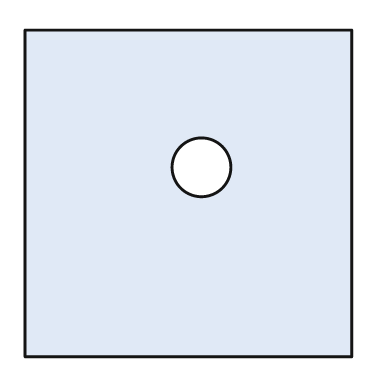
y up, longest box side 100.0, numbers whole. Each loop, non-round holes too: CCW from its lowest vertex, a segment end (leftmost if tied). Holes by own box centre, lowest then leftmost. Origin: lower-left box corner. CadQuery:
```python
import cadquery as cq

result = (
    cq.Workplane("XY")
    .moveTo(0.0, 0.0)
    .lineTo(100.0, 0.0)
    .lineTo(100.0, 100.0)
    .lineTo(0.0, 100.0)
    .close()
    .moveTo(54.0, 58.0)
    .circle(9.0)
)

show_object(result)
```